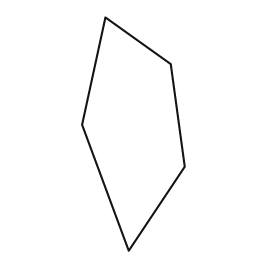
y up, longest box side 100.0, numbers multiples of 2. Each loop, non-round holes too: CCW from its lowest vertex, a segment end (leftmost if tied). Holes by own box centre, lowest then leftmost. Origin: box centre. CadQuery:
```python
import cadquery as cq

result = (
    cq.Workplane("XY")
    .moveTo(-2.0, -50.0)
    .lineTo(22.0, -14.0)
    .lineTo(16.0, 30.0)
    .lineTo(-12.0, 50.0)
    .lineTo(-22.0, 4.0)
    .close()
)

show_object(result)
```